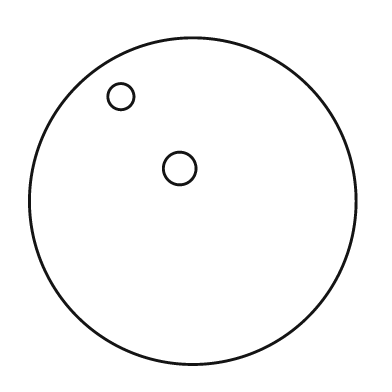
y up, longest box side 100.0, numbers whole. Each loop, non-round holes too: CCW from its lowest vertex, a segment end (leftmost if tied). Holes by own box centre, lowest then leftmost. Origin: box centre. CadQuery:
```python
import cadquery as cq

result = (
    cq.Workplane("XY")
    .moveTo(0.0, 0.0)
    .circle(50.0)
    .moveTo(-4.0, 10.0)
    .circle(5.0)
    .moveTo(-22.0, 32.0)
    .circle(4.0)
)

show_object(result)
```